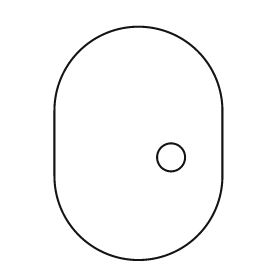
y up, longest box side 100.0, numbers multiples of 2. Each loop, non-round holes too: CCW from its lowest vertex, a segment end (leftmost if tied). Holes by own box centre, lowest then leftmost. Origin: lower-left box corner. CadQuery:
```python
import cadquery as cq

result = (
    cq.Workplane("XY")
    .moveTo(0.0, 36.0)
    .threePointArc((36.0, 0.0), (72.0, 36.0))
    .lineTo(72.0, 64.0)
    .threePointArc((36.0, 100.0), (0.0, 64.0))
    .close()
    .moveTo(50.0, 44.0)
    .circle(6.0)
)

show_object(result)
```